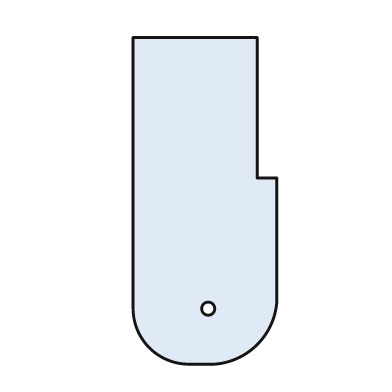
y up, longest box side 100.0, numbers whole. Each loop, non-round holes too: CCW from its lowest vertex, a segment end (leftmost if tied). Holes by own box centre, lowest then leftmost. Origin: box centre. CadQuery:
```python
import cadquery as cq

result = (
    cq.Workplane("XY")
    .moveTo(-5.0, -50.0)
    .lineTo(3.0, -50.0)
    .threePointArc((16.0, -44.0), (22.0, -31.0))
    .lineTo(22.0, 7.0)
    .lineTo(16.0, 7.0)
    .lineTo(16.0, 50.0)
    .lineTo(-22.0, 50.0)
    .lineTo(-22.0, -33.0)
    .threePointArc((-17.0, -45.0), (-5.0, -50.0))
    .close()
    .moveTo(1.0, -33.0)
    .circle(2.0)
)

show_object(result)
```